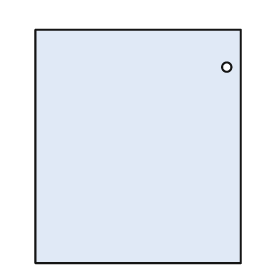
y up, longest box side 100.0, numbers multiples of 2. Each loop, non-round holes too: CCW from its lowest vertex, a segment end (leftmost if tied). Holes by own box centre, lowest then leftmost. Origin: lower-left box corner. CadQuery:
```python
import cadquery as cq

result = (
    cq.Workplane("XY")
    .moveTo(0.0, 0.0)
    .lineTo(88.0, 0.0)
    .lineTo(88.0, 100.0)
    .lineTo(0.0, 100.0)
    .close()
    .moveTo(82.0, 84.0)
    .circle(2.0)
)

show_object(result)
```